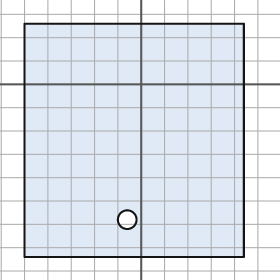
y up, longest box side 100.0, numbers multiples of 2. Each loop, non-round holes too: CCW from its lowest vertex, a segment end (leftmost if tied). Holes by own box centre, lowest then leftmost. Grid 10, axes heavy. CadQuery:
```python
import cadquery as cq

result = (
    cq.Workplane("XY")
    .moveTo(-50.0, -74.0)
    .lineTo(44.0, -74.0)
    .lineTo(44.0, 26.0)
    .lineTo(-50.0, 26.0)
    .close()
    .moveTo(-6.0, -58.0)
    .circle(4.0)
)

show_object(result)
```